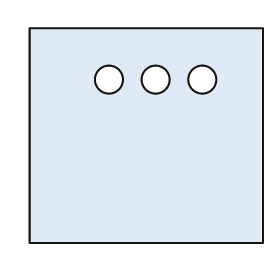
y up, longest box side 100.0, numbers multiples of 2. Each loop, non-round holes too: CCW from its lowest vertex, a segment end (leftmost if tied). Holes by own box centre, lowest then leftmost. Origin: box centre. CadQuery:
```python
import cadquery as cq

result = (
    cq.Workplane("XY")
    .moveTo(-50.0, -46.0)
    .lineTo(50.0, -46.0)
    .lineTo(50.0, 46.0)
    .lineTo(-50.0, 46.0)
    .close()
    .moveTo(-16.0, 24.0)
    .circle(6.0)
    .moveTo(4.0, 24.0)
    .circle(6.0)
    .moveTo(24.0, 24.0)
    .circle(6.0)
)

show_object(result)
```